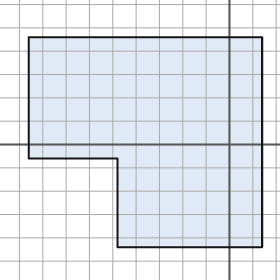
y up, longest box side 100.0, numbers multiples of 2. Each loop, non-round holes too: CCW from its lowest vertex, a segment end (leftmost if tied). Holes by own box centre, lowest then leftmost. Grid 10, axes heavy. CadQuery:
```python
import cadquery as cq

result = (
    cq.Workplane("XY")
    .moveTo(-48.0, -44.0)
    .lineTo(14.0, -44.0)
    .lineTo(14.0, 46.0)
    .lineTo(-86.0, 46.0)
    .lineTo(-86.0, -6.0)
    .lineTo(-48.0, -6.0)
    .close()
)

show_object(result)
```